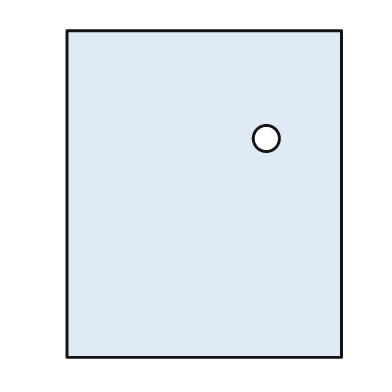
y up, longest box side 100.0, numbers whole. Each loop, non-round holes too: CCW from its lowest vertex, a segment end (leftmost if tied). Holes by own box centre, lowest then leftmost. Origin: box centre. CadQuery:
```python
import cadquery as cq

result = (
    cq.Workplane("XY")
    .moveTo(-42.0, -50.0)
    .lineTo(42.0, -50.0)
    .lineTo(42.0, 50.0)
    .lineTo(-42.0, 50.0)
    .close()
    .moveTo(19.0, 17.0)
    .circle(4.0)
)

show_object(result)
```